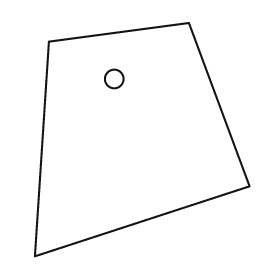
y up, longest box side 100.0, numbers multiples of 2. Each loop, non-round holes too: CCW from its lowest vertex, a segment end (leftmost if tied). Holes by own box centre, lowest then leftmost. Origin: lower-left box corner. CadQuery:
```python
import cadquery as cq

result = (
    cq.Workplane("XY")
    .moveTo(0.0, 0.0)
    .lineTo(92.0, 30.0)
    .lineTo(66.0, 100.0)
    .lineTo(6.0, 92.0)
    .close()
    .moveTo(34.0, 76.0)
    .circle(4.0)
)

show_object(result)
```